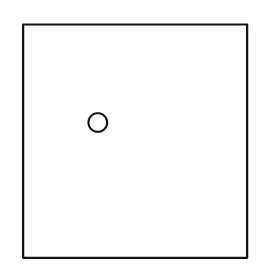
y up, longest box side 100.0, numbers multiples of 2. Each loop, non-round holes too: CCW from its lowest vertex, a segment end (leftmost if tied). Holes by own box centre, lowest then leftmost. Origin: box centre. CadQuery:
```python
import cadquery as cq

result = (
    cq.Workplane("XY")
    .moveTo(-48.0, -50.0)
    .lineTo(48.0, -50.0)
    .lineTo(48.0, 50.0)
    .lineTo(-48.0, 50.0)
    .close()
    .moveTo(-16.0, 8.0)
    .circle(4.0)
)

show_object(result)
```